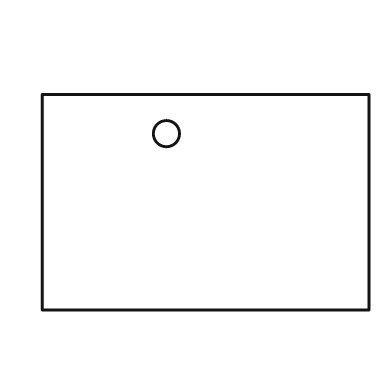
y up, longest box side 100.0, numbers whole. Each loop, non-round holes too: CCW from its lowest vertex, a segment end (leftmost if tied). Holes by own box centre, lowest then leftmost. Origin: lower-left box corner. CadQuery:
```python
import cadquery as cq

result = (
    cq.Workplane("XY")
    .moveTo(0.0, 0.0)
    .lineTo(100.0, 0.0)
    .lineTo(100.0, 66.0)
    .lineTo(0.0, 66.0)
    .close()
    .moveTo(38.0, 54.0)
    .circle(4.0)
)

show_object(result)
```